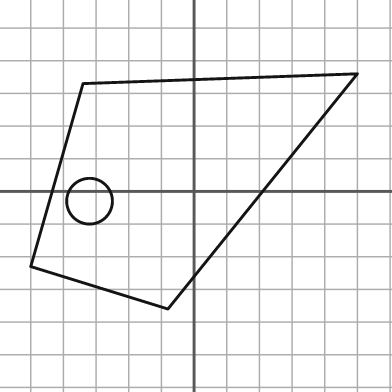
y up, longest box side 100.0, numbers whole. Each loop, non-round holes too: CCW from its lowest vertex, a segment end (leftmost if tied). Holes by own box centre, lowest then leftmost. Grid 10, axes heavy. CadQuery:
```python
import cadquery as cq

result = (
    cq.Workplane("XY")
    .moveTo(-8.0, -36.0)
    .lineTo(50.0, 36.0)
    .lineTo(-34.0, 33.0)
    .lineTo(-50.0, -23.0)
    .close()
    .moveTo(-32.0, -3.0)
    .circle(7.0)
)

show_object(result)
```